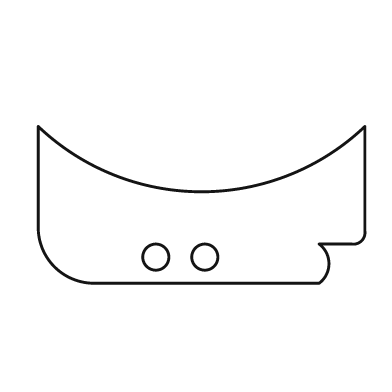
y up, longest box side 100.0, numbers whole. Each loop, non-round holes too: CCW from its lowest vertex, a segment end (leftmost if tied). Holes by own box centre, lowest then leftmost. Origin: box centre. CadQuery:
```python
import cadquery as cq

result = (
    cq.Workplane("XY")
    .moveTo(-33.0, -24.0)
    .lineTo(36.0, -24.0)
    .threePointArc((39.0, -18.0), (36.0, -12.0))
    .lineTo(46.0, -12.0)
    .threePointArc((49.0, -11.0), (50.0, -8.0))
    .lineTo(50.0, 24.0)
    .threePointArc((0.0, 4.0), (-50.0, 24.0))
    .lineTo(-50.0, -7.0)
    .threePointArc((-45.0, -19.0), (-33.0, -24.0))
    .close()
    .moveTo(-14.0, -16.0)
    .circle(4.0)
    .moveTo(1.0, -16.0)
    .circle(4.0)
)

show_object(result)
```